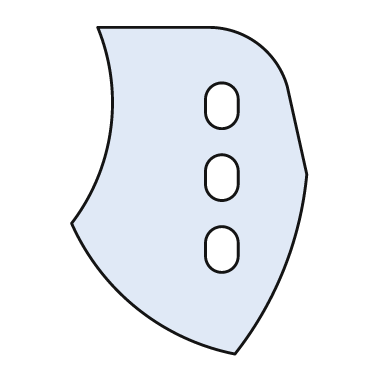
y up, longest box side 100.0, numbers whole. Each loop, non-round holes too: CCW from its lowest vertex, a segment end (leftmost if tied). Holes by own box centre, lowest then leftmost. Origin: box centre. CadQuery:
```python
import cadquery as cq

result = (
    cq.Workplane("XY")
    .moveTo(14.0, -50.0)
    .threePointArc((29.0, -24.0), (36.0, 5.0))
    .lineTo(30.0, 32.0)
    .threePointArc((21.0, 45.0), (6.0, 50.0))
    .lineTo(-28.0, 50.0)
    .threePointArc((-24.0, 19.0), (-36.0, -10.0))
    .threePointArc((-16.0, -36.0), (14.0, -50.0))
    .close()
    .moveTo(5.0, -20.0)
    .threePointArc((10.0, -25.0), (15.0, -20.0))
    .lineTo(15.0, -16.0)
    .threePointArc((10.0, -11.0), (5.0, -16.0))
    .close()
    .moveTo(5.0, 2.0)
    .threePointArc((10.0, -3.0), (15.0, 2.0))
    .lineTo(15.0, 6.0)
    .threePointArc((10.0, 11.0), (5.0, 6.0))
    .close()
    .moveTo(5.0, 24.0)
    .threePointArc((10.0, 19.0), (15.0, 24.0))
    .lineTo(15.0, 28.0)
    .threePointArc((10.0, 33.0), (5.0, 28.0))
    .close()
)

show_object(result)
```